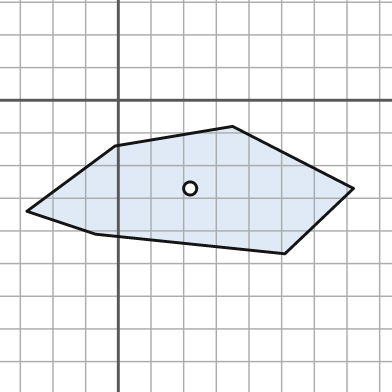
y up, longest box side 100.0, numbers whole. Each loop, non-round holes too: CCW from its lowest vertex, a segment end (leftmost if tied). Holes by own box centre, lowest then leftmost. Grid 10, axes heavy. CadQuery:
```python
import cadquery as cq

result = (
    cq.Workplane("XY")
    .moveTo(51.0, -47.0)
    .lineTo(72.0, -27.0)
    .lineTo(35.0, -8.0)
    .lineTo(-1.0, -14.0)
    .lineTo(-28.0, -34.0)
    .lineTo(-7.0, -41.0)
    .close()
    .moveTo(22.0, -27.0)
    .circle(2.0)
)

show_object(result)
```